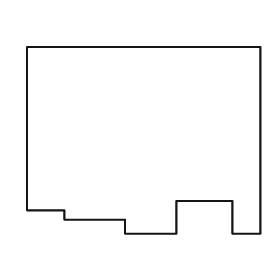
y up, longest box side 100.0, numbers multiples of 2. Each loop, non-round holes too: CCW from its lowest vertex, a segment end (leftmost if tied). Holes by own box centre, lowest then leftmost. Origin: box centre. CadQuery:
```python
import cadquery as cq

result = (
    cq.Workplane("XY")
    .moveTo(-8.0, -40.0)
    .lineTo(14.0, -40.0)
    .lineTo(14.0, -26.0)
    .lineTo(38.0, -26.0)
    .lineTo(38.0, -40.0)
    .lineTo(50.0, -40.0)
    .lineTo(50.0, 40.0)
    .lineTo(-50.0, 40.0)
    .lineTo(-50.0, -30.0)
    .lineTo(-34.0, -30.0)
    .lineTo(-34.0, -34.0)
    .lineTo(-8.0, -34.0)
    .close()
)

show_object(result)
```